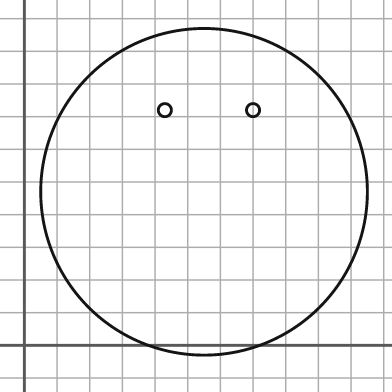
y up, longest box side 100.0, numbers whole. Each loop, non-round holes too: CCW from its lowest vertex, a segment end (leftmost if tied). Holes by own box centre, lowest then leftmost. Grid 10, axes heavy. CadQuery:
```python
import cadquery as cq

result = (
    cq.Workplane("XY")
    .moveTo(55.0, 47.0)
    .circle(50.0)
    .moveTo(43.0, 72.0)
    .circle(2.0)
    .moveTo(70.0, 72.0)
    .circle(2.0)
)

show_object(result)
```